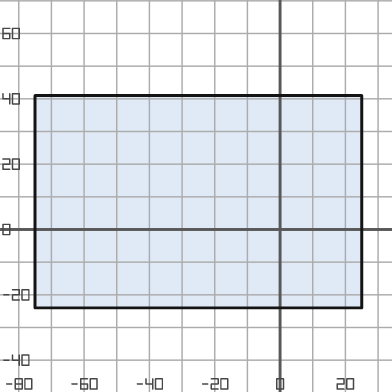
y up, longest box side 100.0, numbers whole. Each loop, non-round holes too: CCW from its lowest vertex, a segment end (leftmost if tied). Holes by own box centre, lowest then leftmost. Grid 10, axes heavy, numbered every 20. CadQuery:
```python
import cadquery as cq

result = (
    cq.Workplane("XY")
    .moveTo(-75.0, -24.0)
    .lineTo(25.0, -24.0)
    .lineTo(25.0, 41.0)
    .lineTo(-75.0, 41.0)
    .close()
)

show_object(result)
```